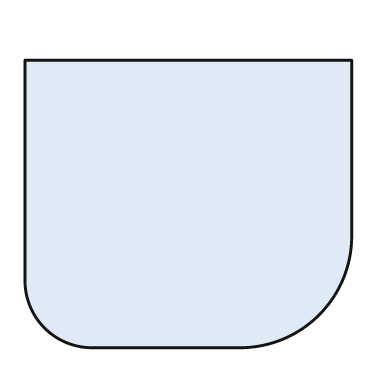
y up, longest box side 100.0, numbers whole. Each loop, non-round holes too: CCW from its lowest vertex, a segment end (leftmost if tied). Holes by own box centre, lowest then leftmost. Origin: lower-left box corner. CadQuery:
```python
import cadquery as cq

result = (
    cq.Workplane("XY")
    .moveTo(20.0, 0.0)
    .lineTo(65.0, 0.0)
    .threePointArc((90.0, 10.0), (100.0, 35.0))
    .lineTo(100.0, 88.0)
    .lineTo(0.0, 88.0)
    .lineTo(0.0, 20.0)
    .threePointArc((6.0, 6.0), (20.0, 0.0))
    .close()
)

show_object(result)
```